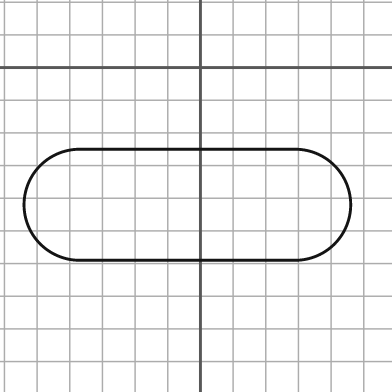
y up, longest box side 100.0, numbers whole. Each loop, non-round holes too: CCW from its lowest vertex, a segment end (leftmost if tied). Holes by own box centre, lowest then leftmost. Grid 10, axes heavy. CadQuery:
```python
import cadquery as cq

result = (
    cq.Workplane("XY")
    .moveTo(-37.0, -59.0)
    .lineTo(29.0, -59.0)
    .threePointArc((46.0, -42.0), (29.0, -25.0))
    .lineTo(-37.0, -25.0)
    .threePointArc((-54.0, -42.0), (-37.0, -59.0))
    .close()
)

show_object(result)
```